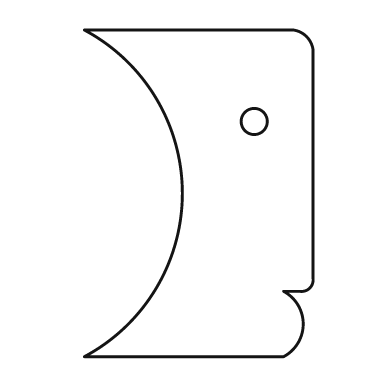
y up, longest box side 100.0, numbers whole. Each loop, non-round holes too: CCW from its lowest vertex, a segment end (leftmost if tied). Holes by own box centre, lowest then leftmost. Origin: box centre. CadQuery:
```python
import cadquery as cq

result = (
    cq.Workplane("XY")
    .moveTo(-35.0, -50.0)
    .lineTo(26.0, -50.0)
    .threePointArc((32.0, -40.0), (26.0, -30.0))
    .lineTo(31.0, -30.0)
    .threePointArc((34.0, -29.0), (35.0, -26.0))
    .lineTo(35.0, 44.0)
    .threePointArc((33.0, 48.0), (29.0, 50.0))
    .lineTo(-35.0, 50.0)
    .threePointArc((-5.0, 0.0), (-35.0, -50.0))
    .close()
    .moveTo(17.0, 22.0)
    .circle(4.0)
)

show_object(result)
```